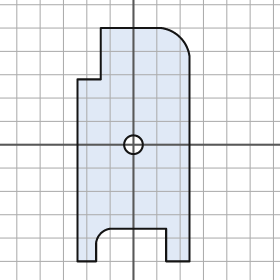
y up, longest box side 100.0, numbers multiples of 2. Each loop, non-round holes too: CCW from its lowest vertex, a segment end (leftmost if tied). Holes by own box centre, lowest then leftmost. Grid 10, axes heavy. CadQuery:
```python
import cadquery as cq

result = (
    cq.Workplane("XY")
    .moveTo(-24.0, -50.0)
    .lineTo(-16.0, -50.0)
    .lineTo(-16.0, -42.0)
    .threePointArc((-14.0, -38.0), (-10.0, -36.0))
    .lineTo(14.0, -36.0)
    .lineTo(14.0, -50.0)
    .lineTo(24.0, -50.0)
    .lineTo(24.0, 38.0)
    .threePointArc((20.0, 46.0), (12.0, 50.0))
    .lineTo(-14.0, 50.0)
    .lineTo(-14.0, 28.0)
    .lineTo(-24.0, 28.0)
    .close()
    .moveTo(0.0, 0.0)
    .circle(4.0)
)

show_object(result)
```